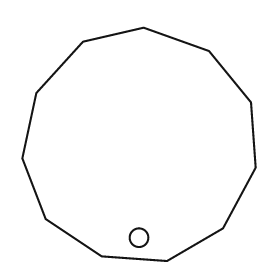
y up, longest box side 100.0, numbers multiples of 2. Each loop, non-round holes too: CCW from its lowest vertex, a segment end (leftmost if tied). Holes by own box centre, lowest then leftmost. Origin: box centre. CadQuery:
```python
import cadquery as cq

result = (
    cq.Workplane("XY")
    .moveTo(12.0, -50.0)
    .lineTo(36.0, -36.0)
    .lineTo(50.0, -10.0)
    .lineTo(48.0, 18.0)
    .lineTo(30.0, 40.0)
    .lineTo(2.0, 50.0)
    .lineTo(-24.0, 44.0)
    .lineTo(-44.0, 22.0)
    .lineTo(-50.0, -6.0)
    .lineTo(-40.0, -32.0)
    .lineTo(-16.0, -48.0)
    .close()
    .moveTo(0.0, -40.0)
    .circle(4.0)
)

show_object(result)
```